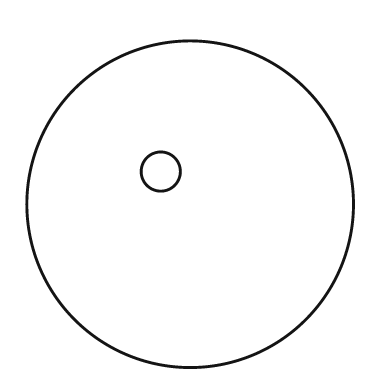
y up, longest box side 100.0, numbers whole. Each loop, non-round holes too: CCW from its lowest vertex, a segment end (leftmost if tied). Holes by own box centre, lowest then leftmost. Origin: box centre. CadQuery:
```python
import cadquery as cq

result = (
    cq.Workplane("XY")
    .moveTo(0.0, 0.0)
    .circle(50.0)
    .moveTo(-9.0, 10.0)
    .circle(6.0)
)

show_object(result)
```